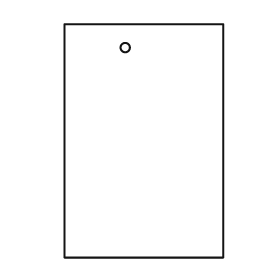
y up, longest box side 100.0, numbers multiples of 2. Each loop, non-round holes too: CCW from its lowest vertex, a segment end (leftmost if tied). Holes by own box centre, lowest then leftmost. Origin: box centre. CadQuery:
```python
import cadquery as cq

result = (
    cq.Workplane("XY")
    .moveTo(-34.0, -50.0)
    .lineTo(34.0, -50.0)
    .lineTo(34.0, 50.0)
    .lineTo(-34.0, 50.0)
    .close()
    .moveTo(-8.0, 40.0)
    .circle(2.0)
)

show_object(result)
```